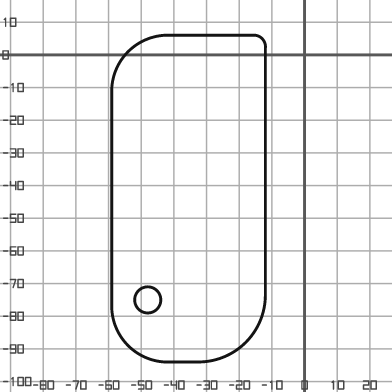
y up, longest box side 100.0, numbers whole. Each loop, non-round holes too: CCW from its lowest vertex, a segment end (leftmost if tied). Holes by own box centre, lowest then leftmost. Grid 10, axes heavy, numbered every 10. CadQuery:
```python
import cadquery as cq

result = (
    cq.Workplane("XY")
    .moveTo(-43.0, -94.0)
    .lineTo(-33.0, -94.0)
    .threePointArc((-18.0, -88.0), (-12.0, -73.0))
    .lineTo(-12.0, 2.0)
    .threePointArc((-13.0, 5.0), (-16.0, 6.0))
    .lineTo(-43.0, 6.0)
    .threePointArc((-54.0, 1.0), (-59.0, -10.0))
    .lineTo(-59.0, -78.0)
    .threePointArc((-54.0, -89.0), (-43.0, -94.0))
    .close()
    .moveTo(-48.0, -75.0)
    .circle(4.0)
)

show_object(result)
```